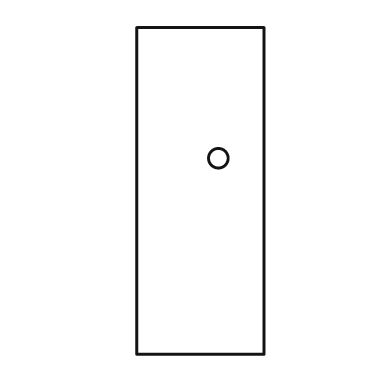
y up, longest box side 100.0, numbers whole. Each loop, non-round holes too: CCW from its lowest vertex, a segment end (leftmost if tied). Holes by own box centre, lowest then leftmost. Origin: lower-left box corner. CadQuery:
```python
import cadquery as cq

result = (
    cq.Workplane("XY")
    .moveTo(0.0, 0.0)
    .lineTo(39.0, 0.0)
    .lineTo(39.0, 100.0)
    .lineTo(0.0, 100.0)
    .close()
    .moveTo(25.0, 60.0)
    .circle(3.0)
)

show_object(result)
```